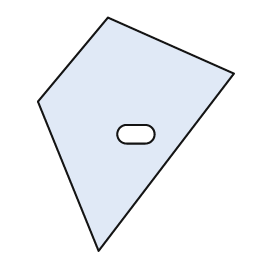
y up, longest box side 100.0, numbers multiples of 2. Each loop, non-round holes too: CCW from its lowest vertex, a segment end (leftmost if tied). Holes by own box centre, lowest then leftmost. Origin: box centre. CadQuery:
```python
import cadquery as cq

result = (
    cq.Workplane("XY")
    .moveTo(-16.0, -50.0)
    .lineTo(42.0, 26.0)
    .lineTo(-12.0, 50.0)
    .lineTo(-42.0, 14.0)
    .close()
    .moveTo(-4.0, -4.0)
    .lineTo(4.0, -4.0)
    .threePointArc((8.0, 0.0), (4.0, 4.0))
    .lineTo(-4.0, 4.0)
    .threePointArc((-8.0, 0.0), (-4.0, -4.0))
    .close()
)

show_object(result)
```